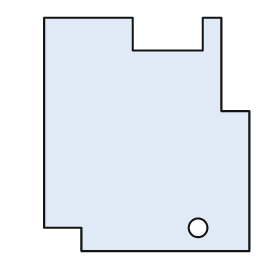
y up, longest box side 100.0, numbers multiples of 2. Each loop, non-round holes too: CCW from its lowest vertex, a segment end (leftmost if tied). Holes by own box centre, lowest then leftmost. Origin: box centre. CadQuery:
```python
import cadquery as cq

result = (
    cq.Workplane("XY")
    .moveTo(-28.0, -50.0)
    .lineTo(44.0, -50.0)
    .lineTo(44.0, 10.0)
    .lineTo(32.0, 10.0)
    .lineTo(32.0, 50.0)
    .lineTo(24.0, 50.0)
    .lineTo(24.0, 36.0)
    .lineTo(-6.0, 36.0)
    .lineTo(-6.0, 50.0)
    .lineTo(-44.0, 50.0)
    .lineTo(-44.0, -40.0)
    .lineTo(-28.0, -40.0)
    .close()
    .moveTo(22.0, -40.0)
    .circle(4.0)
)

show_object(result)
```